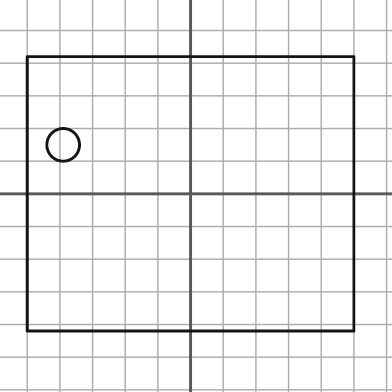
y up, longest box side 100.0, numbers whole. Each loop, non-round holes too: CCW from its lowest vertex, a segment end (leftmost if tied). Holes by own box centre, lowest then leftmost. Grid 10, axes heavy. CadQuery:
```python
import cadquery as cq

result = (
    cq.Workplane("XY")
    .moveTo(-50.0, -42.0)
    .lineTo(50.0, -42.0)
    .lineTo(50.0, 42.0)
    .lineTo(-50.0, 42.0)
    .close()
    .moveTo(-39.0, 15.0)
    .circle(5.0)
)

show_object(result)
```